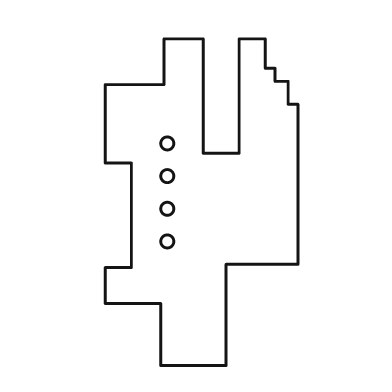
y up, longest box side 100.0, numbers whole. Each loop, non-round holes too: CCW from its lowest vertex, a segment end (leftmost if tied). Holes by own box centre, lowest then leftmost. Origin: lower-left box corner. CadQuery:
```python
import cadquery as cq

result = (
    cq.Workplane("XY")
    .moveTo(17.0, 0.0)
    .lineTo(37.0, 0.0)
    .lineTo(37.0, 31.0)
    .lineTo(59.0, 31.0)
    .lineTo(59.0, 80.0)
    .lineTo(56.0, 80.0)
    .lineTo(56.0, 87.0)
    .lineTo(52.0, 87.0)
    .lineTo(52.0, 91.0)
    .lineTo(49.0, 91.0)
    .lineTo(49.0, 100.0)
    .lineTo(41.0, 100.0)
    .lineTo(41.0, 65.0)
    .lineTo(30.0, 65.0)
    .lineTo(30.0, 100.0)
    .lineTo(18.0, 100.0)
    .lineTo(18.0, 86.0)
    .lineTo(0.0, 86.0)
    .lineTo(0.0, 62.0)
    .lineTo(8.0, 62.0)
    .lineTo(8.0, 30.0)
    .lineTo(0.0, 30.0)
    .lineTo(0.0, 19.0)
    .lineTo(17.0, 19.0)
    .close()
    .moveTo(19.0, 38.0)
    .circle(2.0)
    .moveTo(19.0, 48.0)
    .circle(2.0)
    .moveTo(19.0, 58.0)
    .circle(2.0)
    .moveTo(19.0, 68.0)
    .circle(2.0)
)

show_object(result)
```